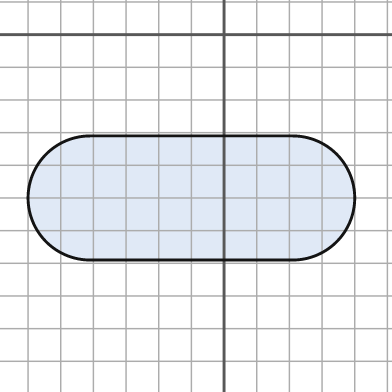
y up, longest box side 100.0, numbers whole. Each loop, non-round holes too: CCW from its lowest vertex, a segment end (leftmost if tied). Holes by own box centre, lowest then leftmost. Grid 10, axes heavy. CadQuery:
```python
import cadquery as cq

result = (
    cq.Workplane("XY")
    .moveTo(-41.0, -69.0)
    .lineTo(21.0, -69.0)
    .threePointArc((40.0, -50.0), (21.0, -31.0))
    .lineTo(-41.0, -31.0)
    .threePointArc((-60.0, -50.0), (-41.0, -69.0))
    .close()
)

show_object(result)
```